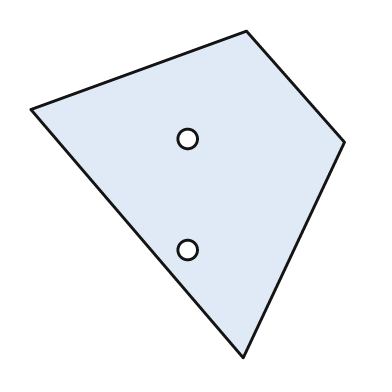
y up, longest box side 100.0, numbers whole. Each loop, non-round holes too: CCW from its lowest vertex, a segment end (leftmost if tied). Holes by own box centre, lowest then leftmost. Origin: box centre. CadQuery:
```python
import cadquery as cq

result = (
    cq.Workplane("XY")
    .moveTo(17.0, -50.0)
    .lineTo(48.0, 16.0)
    .lineTo(18.0, 50.0)
    .lineTo(-48.0, 26.0)
    .close()
    .moveTo(0.0, -17.0)
    .circle(3.0)
    .moveTo(0.0, 17.0)
    .circle(3.0)
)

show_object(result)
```